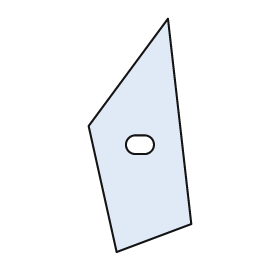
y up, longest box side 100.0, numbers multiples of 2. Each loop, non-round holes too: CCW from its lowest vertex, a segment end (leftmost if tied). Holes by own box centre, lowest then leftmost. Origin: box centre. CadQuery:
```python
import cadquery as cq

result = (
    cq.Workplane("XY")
    .moveTo(-10.0, -50.0)
    .lineTo(22.0, -38.0)
    .lineTo(12.0, 50.0)
    .lineTo(-22.0, 4.0)
    .close()
    .moveTo(-2.0, -8.0)
    .lineTo(2.0, -8.0)
    .threePointArc((6.0, -4.0), (2.0, 0.0))
    .lineTo(-2.0, 0.0)
    .threePointArc((-6.0, -4.0), (-2.0, -8.0))
    .close()
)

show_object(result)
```